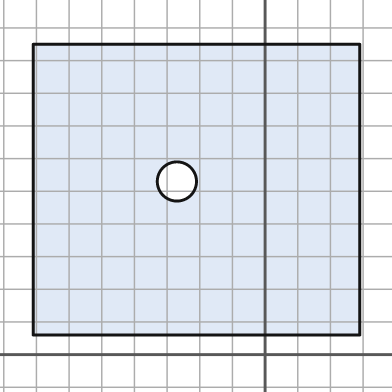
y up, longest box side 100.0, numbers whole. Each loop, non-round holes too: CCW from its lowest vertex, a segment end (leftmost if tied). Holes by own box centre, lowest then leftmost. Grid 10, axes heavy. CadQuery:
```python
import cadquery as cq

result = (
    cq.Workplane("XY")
    .moveTo(-71.0, 6.0)
    .lineTo(29.0, 6.0)
    .lineTo(29.0, 95.0)
    .lineTo(-71.0, 95.0)
    .close()
    .moveTo(-27.0, 53.0)
    .circle(6.0)
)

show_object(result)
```